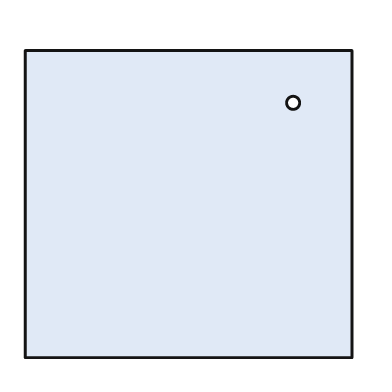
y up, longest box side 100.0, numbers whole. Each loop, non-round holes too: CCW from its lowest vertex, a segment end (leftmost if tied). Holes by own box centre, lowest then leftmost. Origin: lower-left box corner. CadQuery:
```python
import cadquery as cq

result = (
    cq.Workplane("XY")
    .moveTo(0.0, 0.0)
    .lineTo(100.0, 0.0)
    .lineTo(100.0, 94.0)
    .lineTo(0.0, 94.0)
    .close()
    .moveTo(82.0, 78.0)
    .circle(2.0)
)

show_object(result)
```